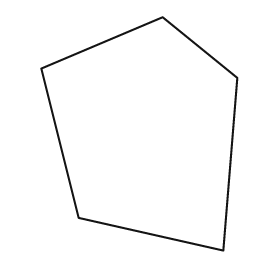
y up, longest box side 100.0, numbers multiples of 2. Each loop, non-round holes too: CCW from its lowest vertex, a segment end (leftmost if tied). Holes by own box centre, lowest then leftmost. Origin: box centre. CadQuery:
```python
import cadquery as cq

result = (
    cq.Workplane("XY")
    .moveTo(36.0, -50.0)
    .lineTo(42.0, 24.0)
    .lineTo(10.0, 50.0)
    .lineTo(-42.0, 28.0)
    .lineTo(-26.0, -36.0)
    .close()
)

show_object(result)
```